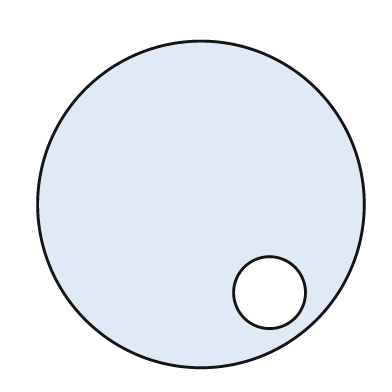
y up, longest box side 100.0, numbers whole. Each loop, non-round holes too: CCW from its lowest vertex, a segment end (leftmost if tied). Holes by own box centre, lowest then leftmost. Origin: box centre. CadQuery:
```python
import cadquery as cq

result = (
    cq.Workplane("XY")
    .moveTo(0.0, 0.0)
    .circle(50.0)
    .moveTo(21.0, -27.0)
    .circle(11.0)
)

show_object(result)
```